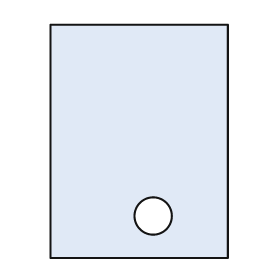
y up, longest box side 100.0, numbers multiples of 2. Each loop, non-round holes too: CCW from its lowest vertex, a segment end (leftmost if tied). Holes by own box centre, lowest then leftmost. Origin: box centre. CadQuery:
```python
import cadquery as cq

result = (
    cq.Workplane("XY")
    .moveTo(-38.0, -50.0)
    .lineTo(38.0, -50.0)
    .lineTo(38.0, 50.0)
    .lineTo(-38.0, 50.0)
    .close()
    .moveTo(6.0, -32.0)
    .circle(8.0)
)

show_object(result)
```